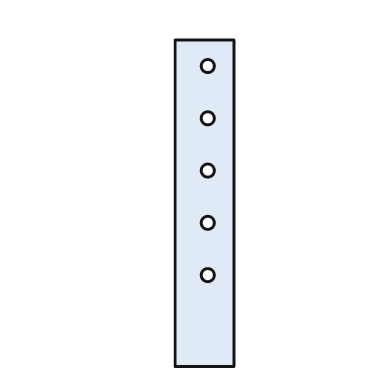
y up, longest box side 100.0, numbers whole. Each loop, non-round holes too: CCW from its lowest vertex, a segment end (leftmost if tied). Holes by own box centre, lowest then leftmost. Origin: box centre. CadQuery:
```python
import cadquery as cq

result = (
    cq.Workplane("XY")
    .moveTo(-9.0, -50.0)
    .lineTo(9.0, -50.0)
    .lineTo(9.0, 50.0)
    .lineTo(-9.0, 50.0)
    .close()
    .moveTo(1.0, -22.0)
    .circle(2.0)
    .moveTo(1.0, -6.0)
    .circle(2.0)
    .moveTo(1.0, 10.0)
    .circle(2.0)
    .moveTo(1.0, 26.0)
    .circle(2.0)
    .moveTo(1.0, 42.0)
    .circle(2.0)
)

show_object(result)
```